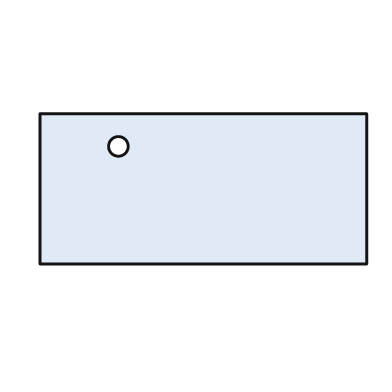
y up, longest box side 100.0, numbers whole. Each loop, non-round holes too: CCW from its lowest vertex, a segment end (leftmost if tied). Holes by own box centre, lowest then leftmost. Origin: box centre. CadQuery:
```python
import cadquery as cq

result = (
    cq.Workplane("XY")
    .moveTo(-50.0, -23.0)
    .lineTo(50.0, -23.0)
    .lineTo(50.0, 23.0)
    .lineTo(-50.0, 23.0)
    .close()
    .moveTo(-26.0, 13.0)
    .circle(3.0)
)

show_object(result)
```